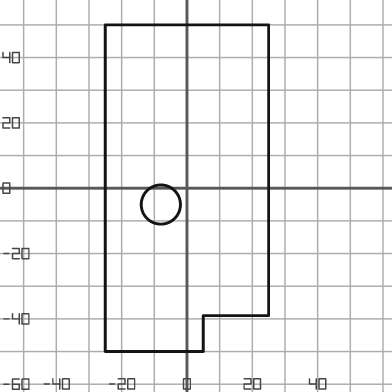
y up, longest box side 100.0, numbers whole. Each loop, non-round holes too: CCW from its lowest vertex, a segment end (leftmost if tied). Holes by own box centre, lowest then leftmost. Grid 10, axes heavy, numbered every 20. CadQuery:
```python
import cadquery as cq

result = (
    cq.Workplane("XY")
    .moveTo(-25.0, -50.0)
    .lineTo(5.0, -50.0)
    .lineTo(5.0, -39.0)
    .lineTo(25.0, -39.0)
    .lineTo(25.0, 50.0)
    .lineTo(-25.0, 50.0)
    .close()
    .moveTo(-8.0, -5.0)
    .circle(6.0)
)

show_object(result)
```